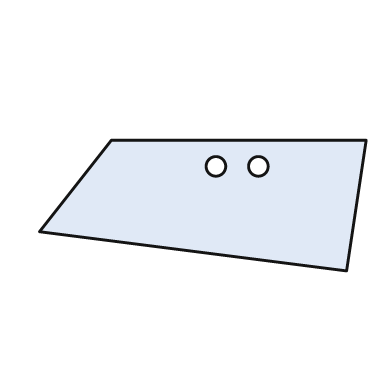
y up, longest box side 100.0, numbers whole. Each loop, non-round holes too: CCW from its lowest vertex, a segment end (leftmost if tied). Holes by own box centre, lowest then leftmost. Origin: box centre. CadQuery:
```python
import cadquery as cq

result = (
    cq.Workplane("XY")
    .moveTo(44.0, -20.0)
    .lineTo(50.0, 20.0)
    .lineTo(-28.0, 20.0)
    .lineTo(-50.0, -8.0)
    .close()
    .moveTo(4.0, 12.0)
    .circle(3.0)
    .moveTo(17.0, 12.0)
    .circle(3.0)
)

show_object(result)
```